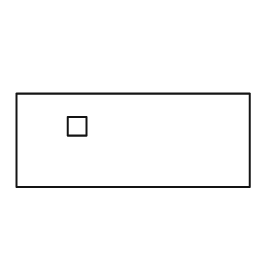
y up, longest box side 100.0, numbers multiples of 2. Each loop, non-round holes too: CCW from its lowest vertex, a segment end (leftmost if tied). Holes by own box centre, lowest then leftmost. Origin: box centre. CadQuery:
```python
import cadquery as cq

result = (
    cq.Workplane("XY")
    .moveTo(-50.0, -20.0)
    .lineTo(50.0, -20.0)
    .lineTo(50.0, 20.0)
    .lineTo(-50.0, 20.0)
    .close()
    .moveTo(-28.0, 2.0)
    .lineTo(-20.0, 2.0)
    .lineTo(-20.0, 10.0)
    .lineTo(-28.0, 10.0)
    .close()
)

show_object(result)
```